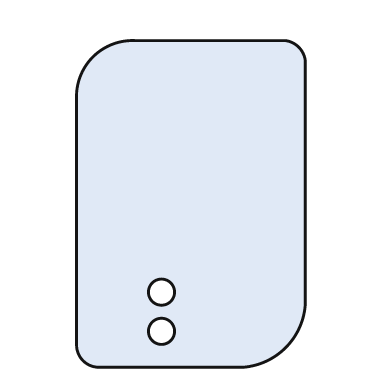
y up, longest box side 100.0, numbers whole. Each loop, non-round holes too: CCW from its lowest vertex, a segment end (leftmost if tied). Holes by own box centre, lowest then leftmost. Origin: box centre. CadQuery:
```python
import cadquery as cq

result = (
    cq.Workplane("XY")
    .moveTo(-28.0, -50.0)
    .lineTo(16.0, -50.0)
    .threePointArc((29.0, -44.0), (35.0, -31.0))
    .lineTo(35.0, 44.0)
    .threePointArc((33.0, 48.0), (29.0, 50.0))
    .lineTo(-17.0, 50.0)
    .threePointArc((-30.0, 45.0), (-35.0, 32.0))
    .lineTo(-35.0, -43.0)
    .threePointArc((-33.0, -48.0), (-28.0, -50.0))
    .close()
    .moveTo(-9.0, -39.0)
    .circle(4.0)
    .moveTo(-9.0, -27.0)
    .circle(4.0)
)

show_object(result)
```